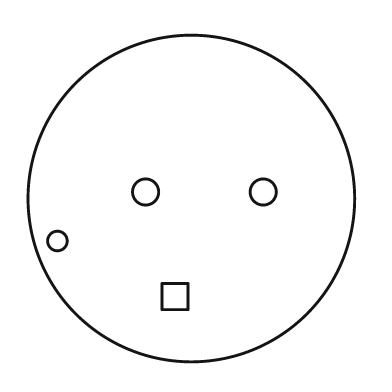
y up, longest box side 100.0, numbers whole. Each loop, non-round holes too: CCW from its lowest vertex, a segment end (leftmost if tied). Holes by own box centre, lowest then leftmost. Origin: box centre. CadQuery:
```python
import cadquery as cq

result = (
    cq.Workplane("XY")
    .moveTo(0.0, 0.0)
    .circle(50.0)
    .moveTo(-9.0, -34.0)
    .lineTo(-1.0, -34.0)
    .lineTo(-1.0, -26.0)
    .lineTo(-9.0, -26.0)
    .close()
    .moveTo(-41.0, -13.0)
    .circle(3.0)
    .moveTo(-14.0, 2.0)
    .circle(4.0)
    .moveTo(22.0, 2.0)
    .circle(4.0)
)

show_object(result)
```